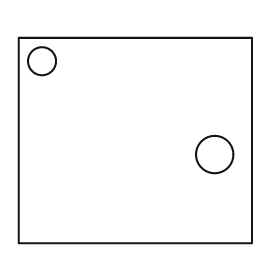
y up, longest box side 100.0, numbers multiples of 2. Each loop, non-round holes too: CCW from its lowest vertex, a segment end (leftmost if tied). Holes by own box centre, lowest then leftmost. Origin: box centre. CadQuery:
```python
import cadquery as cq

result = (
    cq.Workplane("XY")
    .moveTo(-50.0, -44.0)
    .lineTo(50.0, -44.0)
    .lineTo(50.0, 44.0)
    .lineTo(-50.0, 44.0)
    .close()
    .moveTo(34.0, -6.0)
    .circle(8.0)
    .moveTo(-40.0, 34.0)
    .circle(6.0)
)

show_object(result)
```